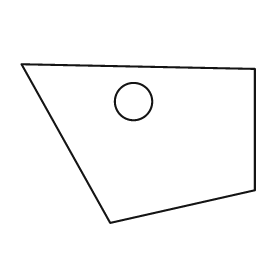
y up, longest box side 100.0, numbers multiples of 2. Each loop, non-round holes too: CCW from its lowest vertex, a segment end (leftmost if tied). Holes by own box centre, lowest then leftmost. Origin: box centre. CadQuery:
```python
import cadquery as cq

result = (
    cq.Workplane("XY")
    .moveTo(-12.0, -34.0)
    .lineTo(50.0, -20.0)
    .lineTo(50.0, 32.0)
    .lineTo(-50.0, 34.0)
    .close()
    .moveTo(-2.0, 18.0)
    .circle(8.0)
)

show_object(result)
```